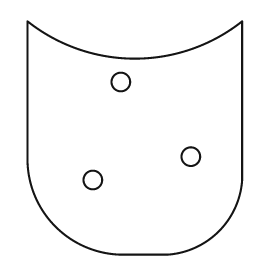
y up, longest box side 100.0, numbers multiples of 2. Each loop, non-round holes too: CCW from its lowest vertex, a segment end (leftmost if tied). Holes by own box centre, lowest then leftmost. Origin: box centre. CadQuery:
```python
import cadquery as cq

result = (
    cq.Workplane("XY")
    .moveTo(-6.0, -50.0)
    .lineTo(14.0, -50.0)
    .threePointArc((36.0, -40.0), (46.0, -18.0))
    .lineTo(46.0, 50.0)
    .threePointArc((0.0, 34.0), (-46.0, 50.0))
    .lineTo(-46.0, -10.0)
    .threePointArc((-34.0, -38.0), (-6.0, -50.0))
    .close()
    .moveTo(-18.0, -18.0)
    .circle(4.0)
    .moveTo(24.0, -8.0)
    .circle(4.0)
    .moveTo(-6.0, 24.0)
    .circle(4.0)
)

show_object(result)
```